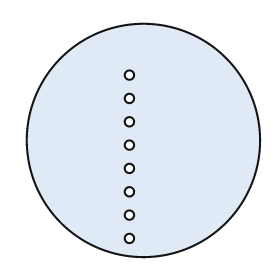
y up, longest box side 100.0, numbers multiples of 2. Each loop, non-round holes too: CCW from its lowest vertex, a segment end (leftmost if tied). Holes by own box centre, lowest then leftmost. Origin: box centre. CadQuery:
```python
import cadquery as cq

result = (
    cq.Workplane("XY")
    .moveTo(0.0, 0.0)
    .circle(50.0)
    .moveTo(-6.0, -42.0)
    .circle(2.0)
    .moveTo(-6.0, -32.0)
    .circle(2.0)
    .moveTo(-6.0, -22.0)
    .circle(2.0)
    .moveTo(-6.0, -12.0)
    .circle(2.0)
    .moveTo(-6.0, -2.0)
    .circle(2.0)
    .moveTo(-6.0, 8.0)
    .circle(2.0)
    .moveTo(-6.0, 18.0)
    .circle(2.0)
    .moveTo(-6.0, 28.0)
    .circle(2.0)
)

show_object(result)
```